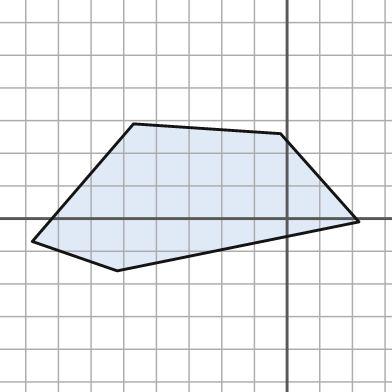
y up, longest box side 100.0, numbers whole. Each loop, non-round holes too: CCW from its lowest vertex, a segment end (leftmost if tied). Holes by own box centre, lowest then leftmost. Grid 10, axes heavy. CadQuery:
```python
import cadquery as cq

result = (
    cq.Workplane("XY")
    .moveTo(-52.0, -16.0)
    .lineTo(22.0, -1.0)
    .lineTo(-2.0, 26.0)
    .lineTo(-47.0, 29.0)
    .lineTo(-78.0, -7.0)
    .close()
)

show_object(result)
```